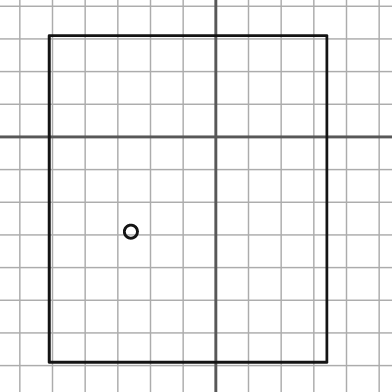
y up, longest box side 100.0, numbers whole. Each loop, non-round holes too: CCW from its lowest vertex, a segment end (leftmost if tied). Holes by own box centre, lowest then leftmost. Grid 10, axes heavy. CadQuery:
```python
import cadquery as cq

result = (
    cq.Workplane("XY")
    .moveTo(-51.0, -69.0)
    .lineTo(34.0, -69.0)
    .lineTo(34.0, 31.0)
    .lineTo(-51.0, 31.0)
    .close()
    .moveTo(-26.0, -29.0)
    .circle(2.0)
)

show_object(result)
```